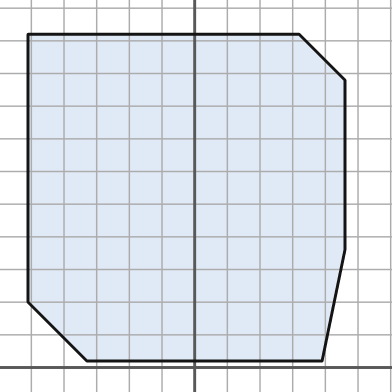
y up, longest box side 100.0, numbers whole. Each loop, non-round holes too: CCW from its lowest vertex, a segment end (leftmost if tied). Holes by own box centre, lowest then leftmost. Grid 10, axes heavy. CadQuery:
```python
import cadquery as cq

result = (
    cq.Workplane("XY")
    .moveTo(-33.0, 2.0)
    .lineTo(39.0, 2.0)
    .lineTo(46.0, 36.0)
    .lineTo(46.0, 88.0)
    .lineTo(32.0, 102.0)
    .lineTo(-51.0, 102.0)
    .lineTo(-51.0, 20.0)
    .close()
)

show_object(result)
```